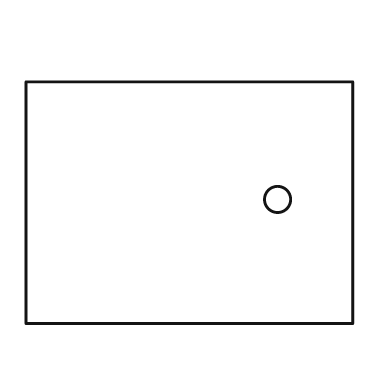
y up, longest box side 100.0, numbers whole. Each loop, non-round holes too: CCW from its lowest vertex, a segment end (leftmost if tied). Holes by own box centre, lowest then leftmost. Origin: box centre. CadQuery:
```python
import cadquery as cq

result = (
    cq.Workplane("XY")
    .moveTo(-50.0, -37.0)
    .lineTo(50.0, -37.0)
    .lineTo(50.0, 37.0)
    .lineTo(-50.0, 37.0)
    .close()
    .moveTo(27.0, 1.0)
    .circle(4.0)
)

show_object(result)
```